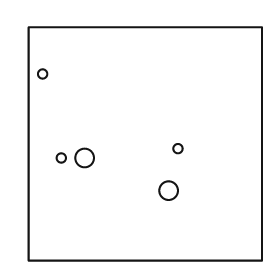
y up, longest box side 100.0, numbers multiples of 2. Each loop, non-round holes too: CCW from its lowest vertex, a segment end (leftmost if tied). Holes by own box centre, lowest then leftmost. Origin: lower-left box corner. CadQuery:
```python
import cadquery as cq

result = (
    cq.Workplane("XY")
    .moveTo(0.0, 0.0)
    .lineTo(100.0, 0.0)
    .lineTo(100.0, 100.0)
    .lineTo(0.0, 100.0)
    .close()
    .moveTo(60.0, 30.0)
    .circle(4.0)
    .moveTo(14.0, 44.0)
    .circle(2.0)
    .moveTo(24.0, 44.0)
    .circle(4.0)
    .moveTo(64.0, 48.0)
    .circle(2.0)
    .moveTo(6.0, 80.0)
    .circle(2.0)
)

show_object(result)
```